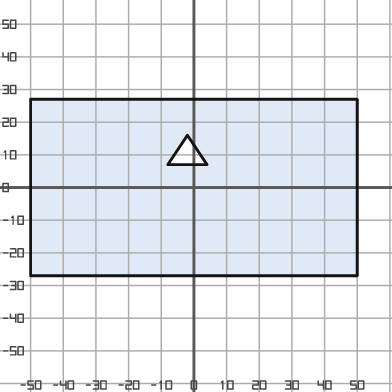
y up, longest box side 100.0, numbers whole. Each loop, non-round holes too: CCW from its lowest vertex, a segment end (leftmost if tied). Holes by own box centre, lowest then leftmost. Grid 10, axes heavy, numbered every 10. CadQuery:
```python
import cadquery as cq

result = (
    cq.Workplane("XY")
    .moveTo(-50.0, -27.0)
    .lineTo(50.0, -27.0)
    .lineTo(50.0, 27.0)
    .lineTo(-50.0, 27.0)
    .close()
    .moveTo(-8.0, 7.0)
    .lineTo(4.0, 7.0)
    .lineTo(-2.0, 16.0)
    .close()
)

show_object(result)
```